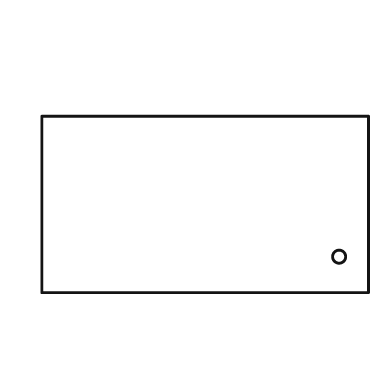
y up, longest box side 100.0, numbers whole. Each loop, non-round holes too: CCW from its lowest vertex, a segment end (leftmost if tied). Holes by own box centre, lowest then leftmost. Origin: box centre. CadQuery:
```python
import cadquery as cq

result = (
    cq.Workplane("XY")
    .moveTo(-50.0, -27.0)
    .lineTo(50.0, -27.0)
    .lineTo(50.0, 27.0)
    .lineTo(-50.0, 27.0)
    .close()
    .moveTo(41.0, -16.0)
    .circle(2.0)
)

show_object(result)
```